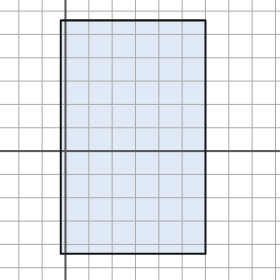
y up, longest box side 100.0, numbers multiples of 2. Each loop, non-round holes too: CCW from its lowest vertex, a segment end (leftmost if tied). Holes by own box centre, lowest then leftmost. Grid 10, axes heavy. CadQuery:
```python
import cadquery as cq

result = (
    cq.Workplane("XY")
    .moveTo(-2.0, -44.0)
    .lineTo(60.0, -44.0)
    .lineTo(60.0, 56.0)
    .lineTo(-2.0, 56.0)
    .close()
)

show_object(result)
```